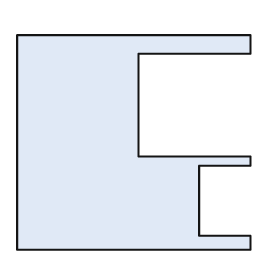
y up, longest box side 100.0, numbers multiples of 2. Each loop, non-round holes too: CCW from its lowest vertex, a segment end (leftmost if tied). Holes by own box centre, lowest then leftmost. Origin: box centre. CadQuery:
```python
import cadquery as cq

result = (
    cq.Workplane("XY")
    .moveTo(-50.0, -46.0)
    .lineTo(50.0, -46.0)
    .lineTo(50.0, -40.0)
    .lineTo(28.0, -40.0)
    .lineTo(28.0, -10.0)
    .lineTo(50.0, -10.0)
    .lineTo(50.0, -6.0)
    .lineTo(2.0, -6.0)
    .lineTo(2.0, 38.0)
    .lineTo(50.0, 38.0)
    .lineTo(50.0, 46.0)
    .lineTo(-50.0, 46.0)
    .close()
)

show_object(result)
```